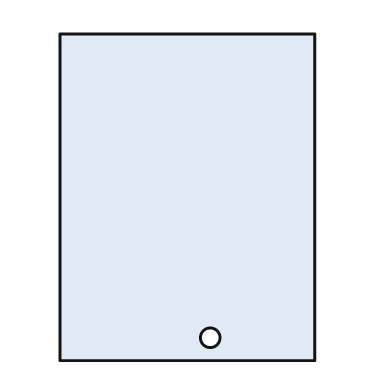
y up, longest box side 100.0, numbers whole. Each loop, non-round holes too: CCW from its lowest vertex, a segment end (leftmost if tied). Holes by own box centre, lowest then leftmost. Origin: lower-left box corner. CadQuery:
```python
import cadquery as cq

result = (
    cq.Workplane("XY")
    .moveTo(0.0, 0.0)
    .lineTo(78.0, 0.0)
    .lineTo(78.0, 100.0)
    .lineTo(0.0, 100.0)
    .close()
    .moveTo(46.0, 7.0)
    .circle(3.0)
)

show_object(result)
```